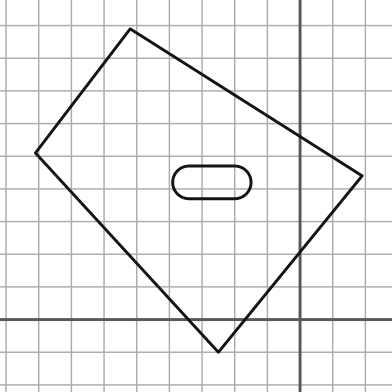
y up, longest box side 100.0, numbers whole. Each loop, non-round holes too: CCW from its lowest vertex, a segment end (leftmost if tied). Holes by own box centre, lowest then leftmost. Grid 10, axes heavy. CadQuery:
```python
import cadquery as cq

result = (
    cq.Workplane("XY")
    .moveTo(-25.0, -10.0)
    .lineTo(19.0, 44.0)
    .lineTo(-52.0, 89.0)
    .lineTo(-81.0, 51.0)
    .close()
    .moveTo(-34.0, 37.0)
    .lineTo(-20.0, 37.0)
    .threePointArc((-15.0, 42.0), (-20.0, 47.0))
    .lineTo(-34.0, 47.0)
    .threePointArc((-39.0, 42.0), (-34.0, 37.0))
    .close()
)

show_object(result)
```